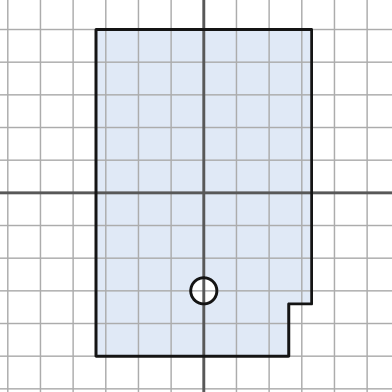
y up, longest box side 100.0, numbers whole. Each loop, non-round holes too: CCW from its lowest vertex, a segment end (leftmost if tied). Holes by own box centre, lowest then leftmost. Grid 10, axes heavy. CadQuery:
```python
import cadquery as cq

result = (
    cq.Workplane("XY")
    .moveTo(-33.0, -50.0)
    .lineTo(26.0, -50.0)
    .lineTo(26.0, -34.0)
    .lineTo(33.0, -34.0)
    .lineTo(33.0, 50.0)
    .lineTo(-33.0, 50.0)
    .close()
    .moveTo(0.0, -30.0)
    .circle(4.0)
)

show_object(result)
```